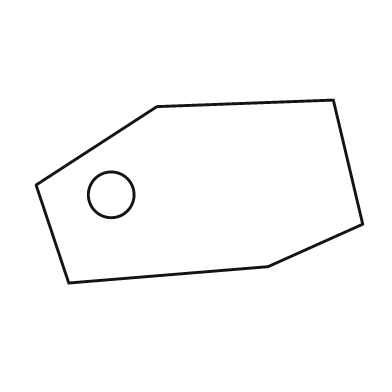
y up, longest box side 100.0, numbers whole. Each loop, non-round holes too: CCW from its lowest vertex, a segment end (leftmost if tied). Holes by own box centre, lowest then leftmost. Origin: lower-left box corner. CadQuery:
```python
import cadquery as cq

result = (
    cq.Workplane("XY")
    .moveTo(10.0, 0.0)
    .lineTo(71.0, 5.0)
    .lineTo(100.0, 18.0)
    .lineTo(91.0, 56.0)
    .lineTo(37.0, 54.0)
    .lineTo(0.0, 30.0)
    .close()
    .moveTo(23.0, 27.0)
    .circle(7.0)
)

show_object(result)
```